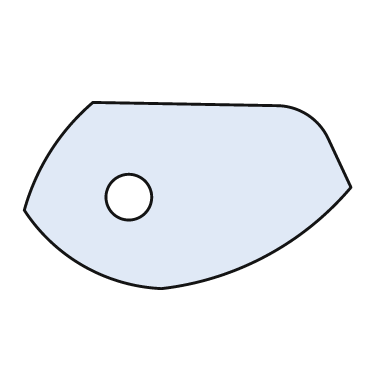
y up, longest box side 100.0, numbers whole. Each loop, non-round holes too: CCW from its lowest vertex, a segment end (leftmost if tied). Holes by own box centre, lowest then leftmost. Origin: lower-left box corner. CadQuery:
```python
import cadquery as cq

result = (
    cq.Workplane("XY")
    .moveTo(42.0, 0.0)
    .threePointArc((74.0, 10.0), (100.0, 31.0))
    .lineTo(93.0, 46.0)
    .threePointArc((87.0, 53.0), (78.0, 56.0))
    .lineTo(21.0, 57.0)
    .threePointArc((8.0, 42.0), (0.0, 24.0))
    .threePointArc((18.0, 7.0), (42.0, 0.0))
    .close()
    .moveTo(32.0, 28.0)
    .circle(7.0)
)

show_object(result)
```